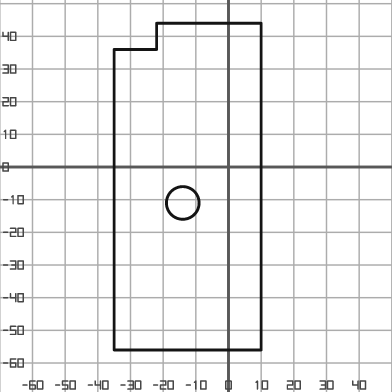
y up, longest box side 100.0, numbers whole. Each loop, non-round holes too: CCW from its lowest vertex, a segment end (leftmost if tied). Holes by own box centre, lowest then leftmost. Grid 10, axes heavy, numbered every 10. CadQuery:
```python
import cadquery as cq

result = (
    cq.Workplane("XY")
    .moveTo(-35.0, -56.0)
    .lineTo(10.0, -56.0)
    .lineTo(10.0, 44.0)
    .lineTo(-22.0, 44.0)
    .lineTo(-22.0, 36.0)
    .lineTo(-35.0, 36.0)
    .close()
    .moveTo(-14.0, -11.0)
    .circle(5.0)
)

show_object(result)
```